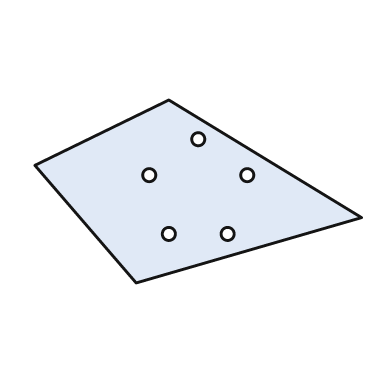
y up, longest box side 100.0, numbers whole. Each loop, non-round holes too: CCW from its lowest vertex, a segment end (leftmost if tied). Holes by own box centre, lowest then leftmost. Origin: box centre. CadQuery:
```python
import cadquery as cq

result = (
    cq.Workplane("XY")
    .moveTo(-19.0, -28.0)
    .lineTo(50.0, -8.0)
    .lineTo(-9.0, 28.0)
    .lineTo(-50.0, 8.0)
    .close()
    .moveTo(-9.0, -13.0)
    .circle(2.0)
    .moveTo(9.0, -13.0)
    .circle(2.0)
    .moveTo(-15.0, 5.0)
    .circle(2.0)
    .moveTo(15.0, 5.0)
    .circle(2.0)
    .moveTo(0.0, 16.0)
    .circle(2.0)
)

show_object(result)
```